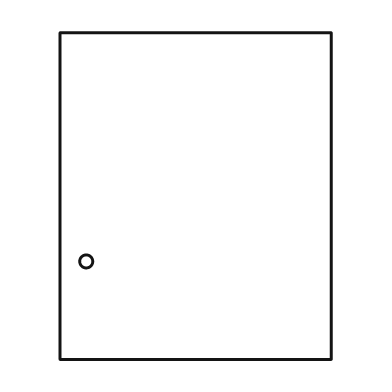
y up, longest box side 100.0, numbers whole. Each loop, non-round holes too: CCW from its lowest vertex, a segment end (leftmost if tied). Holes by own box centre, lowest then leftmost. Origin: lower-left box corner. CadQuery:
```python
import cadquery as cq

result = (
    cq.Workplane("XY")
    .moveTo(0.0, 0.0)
    .lineTo(83.0, 0.0)
    .lineTo(83.0, 100.0)
    .lineTo(0.0, 100.0)
    .close()
    .moveTo(8.0, 30.0)
    .circle(2.0)
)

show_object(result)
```